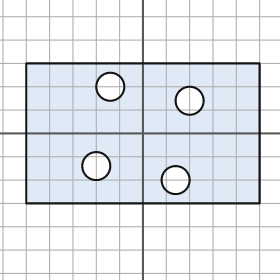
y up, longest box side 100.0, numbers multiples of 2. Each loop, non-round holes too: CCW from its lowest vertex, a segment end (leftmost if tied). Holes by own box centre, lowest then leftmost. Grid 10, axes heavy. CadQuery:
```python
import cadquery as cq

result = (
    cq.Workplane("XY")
    .moveTo(-50.0, -30.0)
    .lineTo(50.0, -30.0)
    .lineTo(50.0, 30.0)
    .lineTo(-50.0, 30.0)
    .close()
    .moveTo(14.0, -20.0)
    .circle(6.0)
    .moveTo(-20.0, -14.0)
    .circle(6.0)
    .moveTo(20.0, 14.0)
    .circle(6.0)
    .moveTo(-14.0, 20.0)
    .circle(6.0)
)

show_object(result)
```